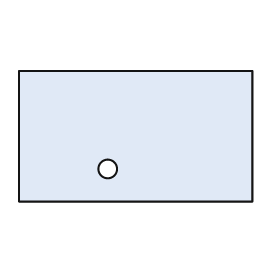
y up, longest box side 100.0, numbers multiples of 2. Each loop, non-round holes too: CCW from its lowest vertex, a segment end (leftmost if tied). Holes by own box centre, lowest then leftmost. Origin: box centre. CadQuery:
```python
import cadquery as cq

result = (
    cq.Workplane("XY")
    .moveTo(-50.0, -28.0)
    .lineTo(50.0, -28.0)
    .lineTo(50.0, 28.0)
    .lineTo(-50.0, 28.0)
    .close()
    .moveTo(-12.0, -14.0)
    .circle(4.0)
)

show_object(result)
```